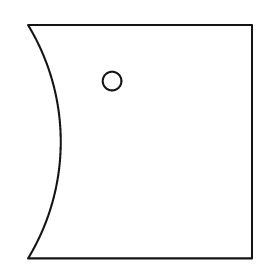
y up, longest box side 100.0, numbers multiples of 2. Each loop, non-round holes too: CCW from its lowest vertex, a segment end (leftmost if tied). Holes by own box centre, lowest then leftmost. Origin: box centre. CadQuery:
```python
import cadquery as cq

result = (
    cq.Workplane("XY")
    .moveTo(-48.0, -50.0)
    .lineTo(48.0, -50.0)
    .lineTo(48.0, 50.0)
    .lineTo(-48.0, 50.0)
    .threePointArc((-34.0, 0.0), (-48.0, -50.0))
    .close()
    .moveTo(-12.0, 26.0)
    .circle(4.0)
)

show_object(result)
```